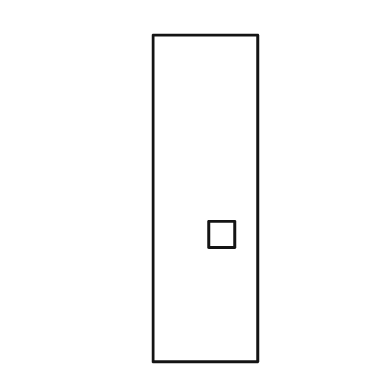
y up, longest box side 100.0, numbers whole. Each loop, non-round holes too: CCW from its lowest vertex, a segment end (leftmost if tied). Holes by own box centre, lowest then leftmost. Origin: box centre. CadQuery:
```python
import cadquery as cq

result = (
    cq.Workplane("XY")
    .moveTo(-16.0, -50.0)
    .lineTo(16.0, -50.0)
    .lineTo(16.0, 50.0)
    .lineTo(-16.0, 50.0)
    .close()
    .moveTo(1.0, -15.0)
    .lineTo(9.0, -15.0)
    .lineTo(9.0, -7.0)
    .lineTo(1.0, -7.0)
    .close()
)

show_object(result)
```